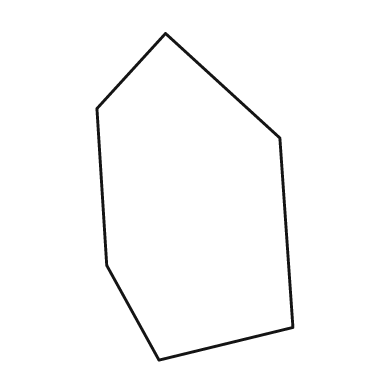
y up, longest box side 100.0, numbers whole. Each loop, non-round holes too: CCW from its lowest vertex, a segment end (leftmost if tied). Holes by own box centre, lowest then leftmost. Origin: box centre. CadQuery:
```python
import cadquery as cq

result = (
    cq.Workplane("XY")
    .moveTo(-11.0, -50.0)
    .lineTo(30.0, -40.0)
    .lineTo(26.0, 18.0)
    .lineTo(-9.0, 50.0)
    .lineTo(-30.0, 27.0)
    .lineTo(-27.0, -21.0)
    .close()
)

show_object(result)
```